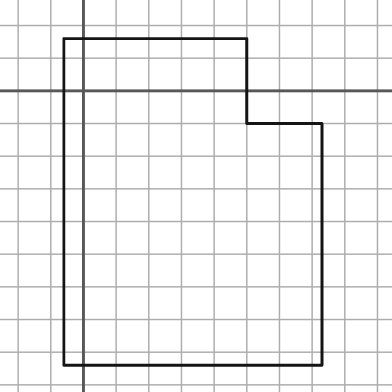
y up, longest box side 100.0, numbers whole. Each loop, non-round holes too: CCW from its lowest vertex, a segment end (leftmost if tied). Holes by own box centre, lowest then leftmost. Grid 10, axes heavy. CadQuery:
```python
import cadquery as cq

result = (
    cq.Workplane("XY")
    .moveTo(-6.0, -84.0)
    .lineTo(73.0, -84.0)
    .lineTo(73.0, -10.0)
    .lineTo(50.0, -10.0)
    .lineTo(50.0, 16.0)
    .lineTo(-6.0, 16.0)
    .close()
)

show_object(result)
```